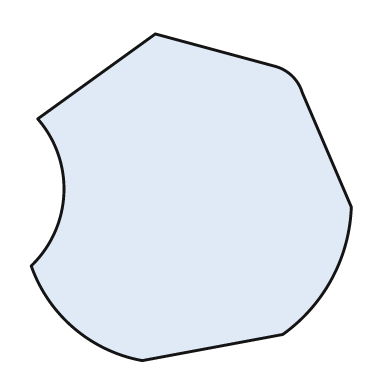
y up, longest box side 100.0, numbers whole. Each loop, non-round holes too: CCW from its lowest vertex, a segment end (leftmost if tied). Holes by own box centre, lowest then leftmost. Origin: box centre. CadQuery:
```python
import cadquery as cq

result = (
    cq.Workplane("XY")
    .moveTo(-15.0, -50.0)
    .lineTo(28.0, -42.0)
    .threePointArc((43.0, -25.0), (49.0, -3.0))
    .lineTo(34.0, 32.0)
    .threePointArc((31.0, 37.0), (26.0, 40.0))
    .lineTo(-11.0, 50.0)
    .lineTo(-47.0, 24.0)
    .threePointArc((-39.0, 1.0), (-49.0, -21.0))
    .threePointArc((-36.0, -40.0), (-15.0, -50.0))
    .close()
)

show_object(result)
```